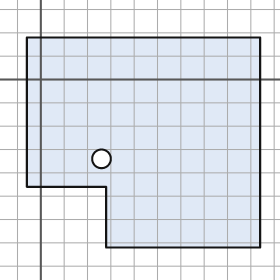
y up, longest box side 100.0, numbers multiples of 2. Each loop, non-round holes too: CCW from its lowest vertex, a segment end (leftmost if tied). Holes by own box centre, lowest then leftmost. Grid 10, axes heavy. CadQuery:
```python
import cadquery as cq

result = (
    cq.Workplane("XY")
    .moveTo(28.0, -72.0)
    .lineTo(94.0, -72.0)
    .lineTo(94.0, 18.0)
    .lineTo(-6.0, 18.0)
    .lineTo(-6.0, -46.0)
    .lineTo(28.0, -46.0)
    .close()
    .moveTo(26.0, -34.0)
    .circle(4.0)
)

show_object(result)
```